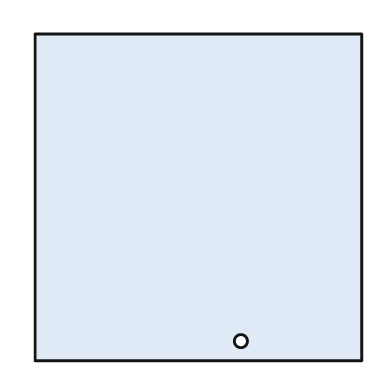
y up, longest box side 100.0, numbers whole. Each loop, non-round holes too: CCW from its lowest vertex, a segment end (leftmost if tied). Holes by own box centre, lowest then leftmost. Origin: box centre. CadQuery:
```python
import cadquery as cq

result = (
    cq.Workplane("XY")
    .moveTo(-50.0, -50.0)
    .lineTo(50.0, -50.0)
    .lineTo(50.0, 50.0)
    .lineTo(-50.0, 50.0)
    .close()
    .moveTo(13.0, -44.0)
    .circle(2.0)
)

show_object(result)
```